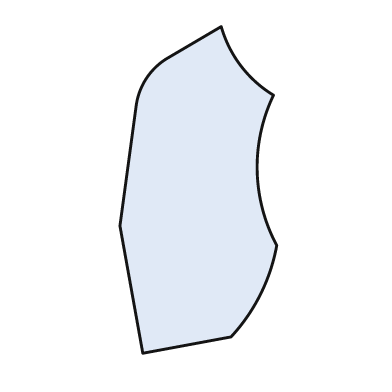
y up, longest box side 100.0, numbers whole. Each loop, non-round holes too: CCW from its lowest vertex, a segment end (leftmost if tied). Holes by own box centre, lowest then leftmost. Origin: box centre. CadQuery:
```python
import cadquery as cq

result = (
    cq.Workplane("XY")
    .moveTo(-17.0, -50.0)
    .lineTo(10.0, -45.0)
    .threePointArc((19.0, -32.0), (24.0, -17.0))
    .threePointArc((18.0, 6.0), (23.0, 29.0))
    .threePointArc((13.0, 38.0), (7.0, 50.0))
    .lineTo(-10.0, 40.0)
    .threePointArc((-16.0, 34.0), (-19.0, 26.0))
    .lineTo(-24.0, -11.0)
    .close()
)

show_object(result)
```